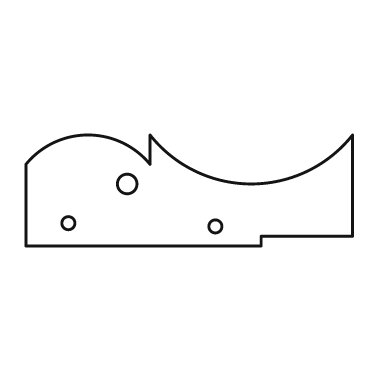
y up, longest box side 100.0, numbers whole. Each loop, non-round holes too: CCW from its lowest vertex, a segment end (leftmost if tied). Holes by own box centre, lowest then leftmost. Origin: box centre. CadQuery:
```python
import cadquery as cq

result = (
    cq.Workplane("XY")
    .moveTo(-50.0, -17.0)
    .lineTo(22.0, -17.0)
    .lineTo(22.0, -14.0)
    .lineTo(50.0, -14.0)
    .lineTo(50.0, 17.0)
    .threePointArc((19.0, 2.0), (-12.0, 17.0))
    .lineTo(-12.0, 8.0)
    .threePointArc((-31.0, 17.0), (-50.0, 8.0))
    .close()
    .moveTo(8.0, -11.0)
    .circle(2.0)
    .moveTo(-37.0, -10.0)
    .circle(2.0)
    .moveTo(-19.0, 2.0)
    .circle(3.0)
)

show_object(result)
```